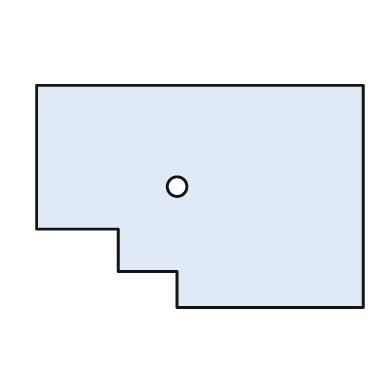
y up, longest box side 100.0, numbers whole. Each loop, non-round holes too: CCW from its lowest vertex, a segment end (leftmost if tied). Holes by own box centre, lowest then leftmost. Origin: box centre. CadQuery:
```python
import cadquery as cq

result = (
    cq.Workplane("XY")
    .moveTo(-7.0, -34.0)
    .lineTo(50.0, -34.0)
    .lineTo(50.0, 34.0)
    .lineTo(-50.0, 34.0)
    .lineTo(-50.0, -10.0)
    .lineTo(-25.0, -10.0)
    .lineTo(-25.0, -23.0)
    .lineTo(-7.0, -23.0)
    .close()
    .moveTo(-7.0, 3.0)
    .circle(3.0)
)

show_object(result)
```